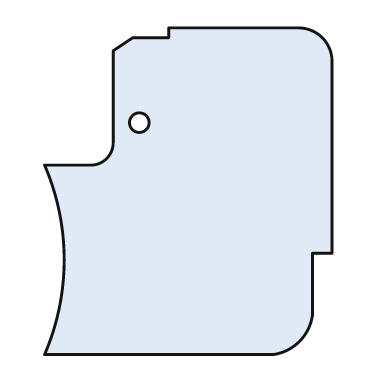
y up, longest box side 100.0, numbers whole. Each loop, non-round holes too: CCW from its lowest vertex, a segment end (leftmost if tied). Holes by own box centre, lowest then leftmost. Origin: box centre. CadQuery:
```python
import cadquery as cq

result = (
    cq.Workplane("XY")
    .moveTo(-44.0, -50.0)
    .lineTo(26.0, -50.0)
    .threePointArc((34.0, -46.0), (38.0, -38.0))
    .lineTo(38.0, -19.0)
    .lineTo(44.0, -19.0)
    .lineTo(44.0, 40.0)
    .threePointArc((41.0, 47.0), (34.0, 50.0))
    .lineTo(-6.0, 50.0)
    .lineTo(-6.0, 47.0)
    .lineTo(-17.0, 47.0)
    .lineTo(-23.0, 43.0)
    .lineTo(-23.0, 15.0)
    .threePointArc((-25.0, 10.0), (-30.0, 8.0))
    .lineTo(-44.0, 8.0)
    .threePointArc((-38.0, -21.0), (-44.0, -50.0))
    .close()
    .moveTo(-15.0, 21.0)
    .circle(3.0)
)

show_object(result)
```